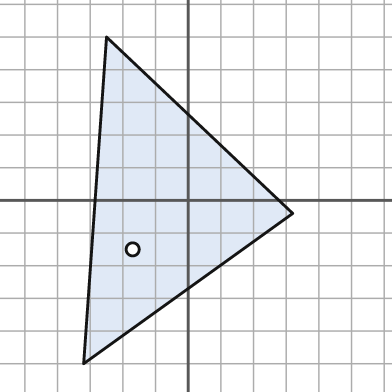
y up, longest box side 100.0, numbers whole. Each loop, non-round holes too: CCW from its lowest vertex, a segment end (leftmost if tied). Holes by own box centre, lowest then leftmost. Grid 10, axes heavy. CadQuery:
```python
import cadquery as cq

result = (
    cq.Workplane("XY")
    .moveTo(-32.0, -50.0)
    .lineTo(32.0, -4.0)
    .lineTo(-25.0, 50.0)
    .close()
    .moveTo(-17.0, -15.0)
    .circle(2.0)
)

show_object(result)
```